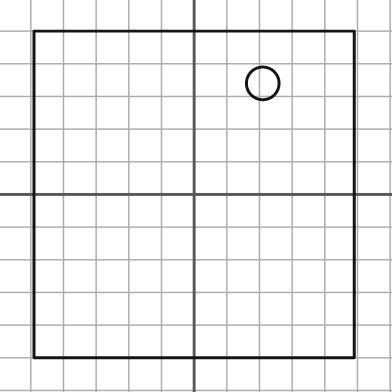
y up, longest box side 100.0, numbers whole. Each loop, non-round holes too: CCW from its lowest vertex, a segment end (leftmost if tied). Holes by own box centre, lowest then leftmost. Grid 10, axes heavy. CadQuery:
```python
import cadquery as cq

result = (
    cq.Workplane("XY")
    .moveTo(-49.0, -50.0)
    .lineTo(49.0, -50.0)
    .lineTo(49.0, 50.0)
    .lineTo(-49.0, 50.0)
    .close()
    .moveTo(21.0, 34.0)
    .circle(5.0)
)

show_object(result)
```